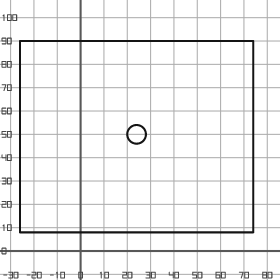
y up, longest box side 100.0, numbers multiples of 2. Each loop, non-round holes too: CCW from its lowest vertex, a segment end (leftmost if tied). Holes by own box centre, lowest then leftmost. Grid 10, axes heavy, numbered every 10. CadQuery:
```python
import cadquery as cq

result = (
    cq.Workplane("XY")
    .moveTo(-26.0, 8.0)
    .lineTo(74.0, 8.0)
    .lineTo(74.0, 90.0)
    .lineTo(-26.0, 90.0)
    .close()
    .moveTo(24.0, 50.0)
    .circle(4.0)
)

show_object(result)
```